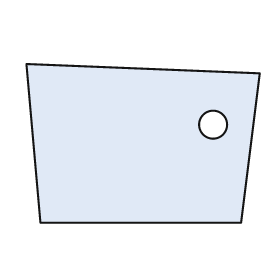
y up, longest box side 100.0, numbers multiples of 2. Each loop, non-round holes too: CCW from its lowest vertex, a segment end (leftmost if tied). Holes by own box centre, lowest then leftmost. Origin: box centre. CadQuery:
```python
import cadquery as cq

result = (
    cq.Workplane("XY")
    .moveTo(-44.0, -34.0)
    .lineTo(42.0, -34.0)
    .lineTo(50.0, 30.0)
    .lineTo(-50.0, 34.0)
    .close()
    .moveTo(30.0, 8.0)
    .circle(6.0)
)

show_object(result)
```